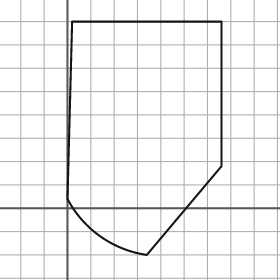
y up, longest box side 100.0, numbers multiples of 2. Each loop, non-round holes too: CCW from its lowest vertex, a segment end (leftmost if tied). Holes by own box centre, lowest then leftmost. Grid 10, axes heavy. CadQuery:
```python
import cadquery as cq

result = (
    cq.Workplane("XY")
    .moveTo(34.0, -20.0)
    .lineTo(66.0, 18.0)
    .lineTo(66.0, 80.0)
    .lineTo(2.0, 80.0)
    .lineTo(0.0, 4.0)
    .threePointArc((14.0, -12.0), (34.0, -20.0))
    .close()
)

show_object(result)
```